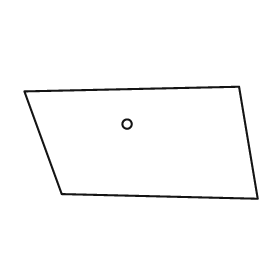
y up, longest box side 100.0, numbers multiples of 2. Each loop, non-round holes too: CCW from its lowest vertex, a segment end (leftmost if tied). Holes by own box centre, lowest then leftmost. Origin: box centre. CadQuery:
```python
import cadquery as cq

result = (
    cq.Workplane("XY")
    .moveTo(50.0, -24.0)
    .lineTo(42.0, 24.0)
    .lineTo(-50.0, 22.0)
    .lineTo(-34.0, -22.0)
    .close()
    .moveTo(-6.0, 8.0)
    .circle(2.0)
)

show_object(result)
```